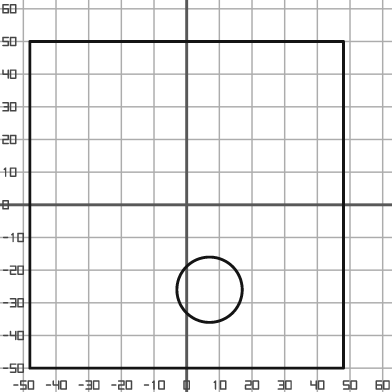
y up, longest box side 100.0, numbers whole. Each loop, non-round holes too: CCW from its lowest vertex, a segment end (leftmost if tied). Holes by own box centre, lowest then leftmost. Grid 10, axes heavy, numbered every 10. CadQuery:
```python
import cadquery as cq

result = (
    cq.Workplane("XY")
    .moveTo(-48.0, -50.0)
    .lineTo(48.0, -50.0)
    .lineTo(48.0, 50.0)
    .lineTo(-48.0, 50.0)
    .close()
    .moveTo(7.0, -26.0)
    .circle(10.0)
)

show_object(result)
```